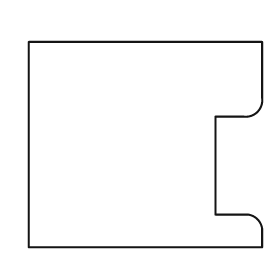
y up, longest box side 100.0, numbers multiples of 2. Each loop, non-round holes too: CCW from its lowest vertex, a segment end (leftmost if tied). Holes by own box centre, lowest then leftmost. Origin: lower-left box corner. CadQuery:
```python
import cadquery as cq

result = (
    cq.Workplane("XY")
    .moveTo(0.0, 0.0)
    .lineTo(100.0, 0.0)
    .lineTo(100.0, 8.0)
    .threePointArc((98.0, 12.0), (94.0, 14.0))
    .lineTo(80.0, 14.0)
    .lineTo(80.0, 56.0)
    .lineTo(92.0, 56.0)
    .threePointArc((98.0, 58.0), (100.0, 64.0))
    .lineTo(100.0, 88.0)
    .lineTo(0.0, 88.0)
    .close()
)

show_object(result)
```